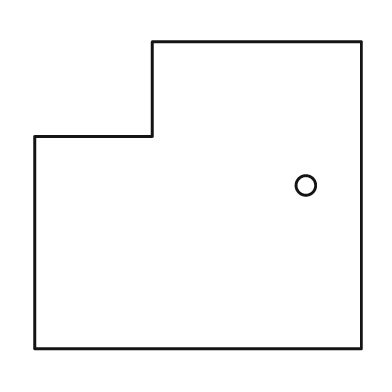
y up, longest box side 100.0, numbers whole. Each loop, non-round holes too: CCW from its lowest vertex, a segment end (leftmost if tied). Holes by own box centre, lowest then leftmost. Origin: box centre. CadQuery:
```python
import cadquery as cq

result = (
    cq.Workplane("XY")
    .moveTo(-50.0, -47.0)
    .lineTo(50.0, -47.0)
    .lineTo(50.0, 47.0)
    .lineTo(-14.0, 47.0)
    .lineTo(-14.0, 18.0)
    .lineTo(-50.0, 18.0)
    .close()
    .moveTo(33.0, 3.0)
    .circle(3.0)
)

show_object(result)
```